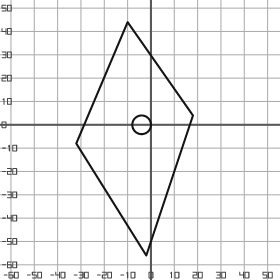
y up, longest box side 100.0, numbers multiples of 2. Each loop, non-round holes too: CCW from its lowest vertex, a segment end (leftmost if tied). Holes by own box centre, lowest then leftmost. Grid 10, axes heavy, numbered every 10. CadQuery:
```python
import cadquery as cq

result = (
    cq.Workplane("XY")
    .moveTo(-2.0, -56.0)
    .lineTo(18.0, 4.0)
    .lineTo(-10.0, 44.0)
    .lineTo(-32.0, -8.0)
    .close()
    .moveTo(-4.0, 0.0)
    .circle(4.0)
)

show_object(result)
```